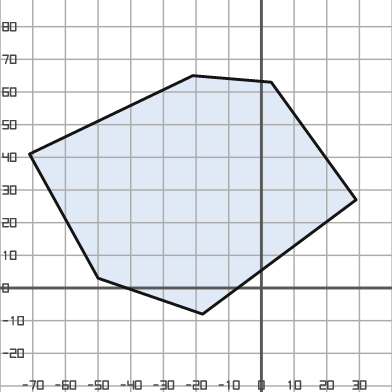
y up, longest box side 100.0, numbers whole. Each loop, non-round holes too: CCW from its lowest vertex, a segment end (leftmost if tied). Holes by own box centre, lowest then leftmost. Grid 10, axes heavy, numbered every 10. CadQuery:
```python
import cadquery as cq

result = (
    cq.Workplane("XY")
    .moveTo(-18.0, -8.0)
    .lineTo(29.0, 27.0)
    .lineTo(3.0, 63.0)
    .lineTo(-21.0, 65.0)
    .lineTo(-71.0, 41.0)
    .lineTo(-50.0, 3.0)
    .close()
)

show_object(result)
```